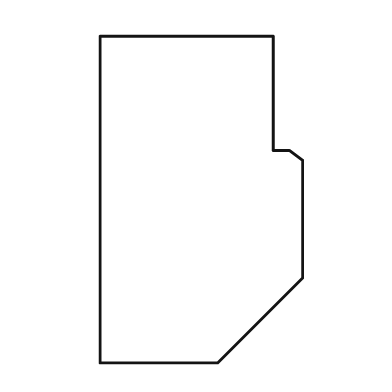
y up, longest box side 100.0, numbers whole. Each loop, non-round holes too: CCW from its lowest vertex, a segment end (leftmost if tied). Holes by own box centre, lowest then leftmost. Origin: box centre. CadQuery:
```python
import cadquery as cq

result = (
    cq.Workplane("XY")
    .moveTo(-31.0, -50.0)
    .lineTo(5.0, -50.0)
    .lineTo(31.0, -24.0)
    .lineTo(31.0, 12.0)
    .lineTo(27.0, 15.0)
    .lineTo(22.0, 15.0)
    .lineTo(22.0, 50.0)
    .lineTo(-31.0, 50.0)
    .close()
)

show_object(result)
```